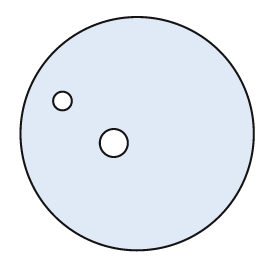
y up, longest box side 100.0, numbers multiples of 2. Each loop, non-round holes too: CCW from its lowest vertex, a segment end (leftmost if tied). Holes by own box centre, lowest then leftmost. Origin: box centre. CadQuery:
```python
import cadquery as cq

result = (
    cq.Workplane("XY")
    .moveTo(0.0, 0.0)
    .circle(50.0)
    .moveTo(-10.0, -4.0)
    .circle(6.0)
    .moveTo(-32.0, 14.0)
    .circle(4.0)
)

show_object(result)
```